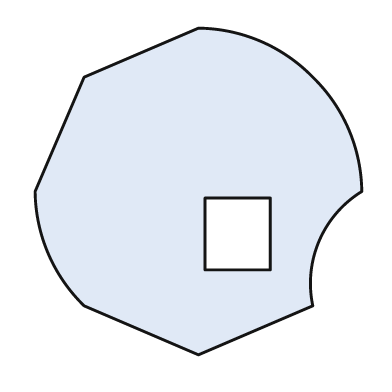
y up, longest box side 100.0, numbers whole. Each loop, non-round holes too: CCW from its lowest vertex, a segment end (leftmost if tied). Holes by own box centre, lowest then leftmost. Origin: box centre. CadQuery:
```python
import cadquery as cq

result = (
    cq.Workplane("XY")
    .moveTo(0.0, -50.0)
    .lineTo(35.0, -35.0)
    .threePointArc((37.0, -15.0), (50.0, 0.0))
    .threePointArc((46.0, 19.0), (35.0, 35.0))
    .threePointArc((19.0, 46.0), (0.0, 50.0))
    .lineTo(-35.0, 35.0)
    .lineTo(-50.0, 0.0)
    .threePointArc((-46.0, -19.0), (-35.0, -35.0))
    .close()
    .moveTo(2.0, -24.0)
    .lineTo(22.0, -24.0)
    .lineTo(22.0, -2.0)
    .lineTo(2.0, -2.0)
    .close()
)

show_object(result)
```